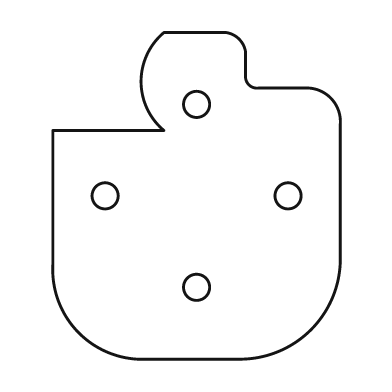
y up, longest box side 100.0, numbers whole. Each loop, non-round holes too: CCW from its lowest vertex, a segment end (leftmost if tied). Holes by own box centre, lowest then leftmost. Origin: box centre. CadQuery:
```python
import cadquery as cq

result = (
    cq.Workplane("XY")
    .moveTo(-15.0, -50.0)
    .lineTo(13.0, -50.0)
    .threePointArc((35.0, -41.0), (44.0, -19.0))
    .lineTo(44.0, 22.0)
    .threePointArc((41.0, 30.0), (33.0, 33.0))
    .lineTo(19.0, 33.0)
    .threePointArc((16.0, 34.0), (15.0, 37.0))
    .lineTo(15.0, 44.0)
    .threePointArc((13.0, 48.0), (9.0, 50.0))
    .lineTo(-10.0, 50.0)
    .threePointArc((-17.0, 35.0), (-10.0, 20.0))
    .lineTo(-44.0, 20.0)
    .lineTo(-44.0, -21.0)
    .threePointArc((-36.0, -42.0), (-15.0, -50.0))
    .close()
    .moveTo(0.0, -28.0)
    .circle(4.0)
    .moveTo(-28.0, 0.0)
    .circle(4.0)
    .moveTo(28.0, 0.0)
    .circle(4.0)
    .moveTo(0.0, 28.0)
    .circle(4.0)
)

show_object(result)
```